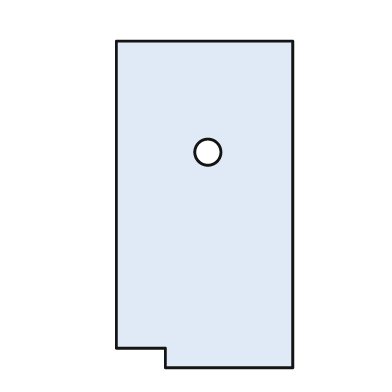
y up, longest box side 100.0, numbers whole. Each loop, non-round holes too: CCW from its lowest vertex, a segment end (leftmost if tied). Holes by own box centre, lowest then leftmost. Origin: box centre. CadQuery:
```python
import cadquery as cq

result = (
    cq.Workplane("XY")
    .moveTo(-12.0, -50.0)
    .lineTo(27.0, -50.0)
    .lineTo(27.0, 50.0)
    .lineTo(-27.0, 50.0)
    .lineTo(-27.0, -44.0)
    .lineTo(-12.0, -44.0)
    .close()
    .moveTo(1.0, 16.0)
    .circle(4.0)
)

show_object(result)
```